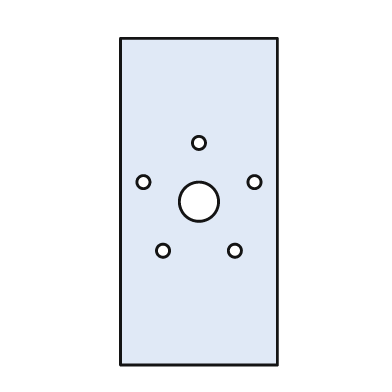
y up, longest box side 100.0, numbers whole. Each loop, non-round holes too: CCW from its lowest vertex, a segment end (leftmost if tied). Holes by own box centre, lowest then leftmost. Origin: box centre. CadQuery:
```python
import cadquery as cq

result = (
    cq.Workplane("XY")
    .moveTo(-24.0, -50.0)
    .lineTo(24.0, -50.0)
    .lineTo(24.0, 50.0)
    .lineTo(-24.0, 50.0)
    .close()
    .moveTo(-11.0, -15.0)
    .circle(2.0)
    .moveTo(11.0, -15.0)
    .circle(2.0)
    .moveTo(0.0, 0.0)
    .circle(6.0)
    .moveTo(-17.0, 6.0)
    .circle(2.0)
    .moveTo(17.0, 6.0)
    .circle(2.0)
    .moveTo(0.0, 18.0)
    .circle(2.0)
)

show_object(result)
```